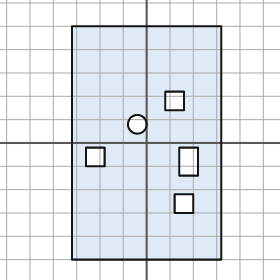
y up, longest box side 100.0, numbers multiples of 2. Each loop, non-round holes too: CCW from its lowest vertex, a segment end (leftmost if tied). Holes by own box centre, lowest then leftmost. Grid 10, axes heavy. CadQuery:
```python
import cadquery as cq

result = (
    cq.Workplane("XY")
    .moveTo(-32.0, -50.0)
    .lineTo(32.0, -50.0)
    .lineTo(32.0, 50.0)
    .lineTo(-32.0, 50.0)
    .close()
    .moveTo(12.0, -30.0)
    .lineTo(20.0, -30.0)
    .lineTo(20.0, -22.0)
    .lineTo(12.0, -22.0)
    .close()
    .moveTo(14.0, -14.0)
    .lineTo(22.0, -14.0)
    .lineTo(22.0, -2.0)
    .lineTo(14.0, -2.0)
    .close()
    .moveTo(-26.0, -10.0)
    .lineTo(-18.0, -10.0)
    .lineTo(-18.0, -2.0)
    .lineTo(-26.0, -2.0)
    .close()
    .moveTo(-4.0, 8.0)
    .circle(4.0)
    .moveTo(8.0, 14.0)
    .lineTo(16.0, 14.0)
    .lineTo(16.0, 22.0)
    .lineTo(8.0, 22.0)
    .close()
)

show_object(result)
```